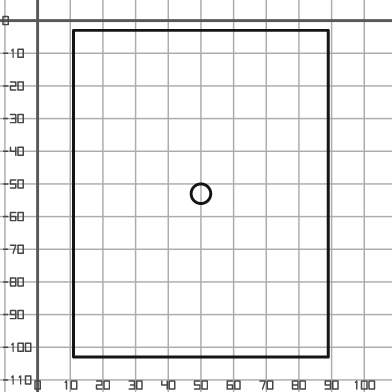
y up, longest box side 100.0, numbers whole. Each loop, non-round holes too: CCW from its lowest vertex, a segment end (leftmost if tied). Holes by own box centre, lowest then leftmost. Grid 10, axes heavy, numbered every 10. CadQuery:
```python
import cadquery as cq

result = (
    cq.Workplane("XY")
    .moveTo(11.0, -103.0)
    .lineTo(89.0, -103.0)
    .lineTo(89.0, -3.0)
    .lineTo(11.0, -3.0)
    .close()
    .moveTo(50.0, -53.0)
    .circle(3.0)
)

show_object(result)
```